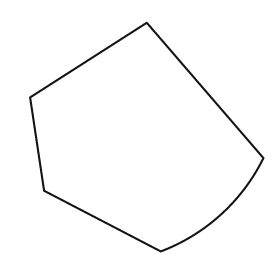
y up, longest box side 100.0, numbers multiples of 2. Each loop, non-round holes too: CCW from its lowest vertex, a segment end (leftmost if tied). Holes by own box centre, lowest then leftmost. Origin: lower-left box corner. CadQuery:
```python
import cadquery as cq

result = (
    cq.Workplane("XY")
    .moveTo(56.0, 0.0)
    .threePointArc((82.0, 16.0), (100.0, 40.0))
    .lineTo(50.0, 98.0)
    .lineTo(0.0, 66.0)
    .lineTo(6.0, 26.0)
    .close()
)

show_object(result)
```